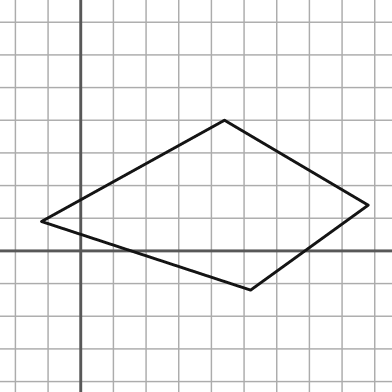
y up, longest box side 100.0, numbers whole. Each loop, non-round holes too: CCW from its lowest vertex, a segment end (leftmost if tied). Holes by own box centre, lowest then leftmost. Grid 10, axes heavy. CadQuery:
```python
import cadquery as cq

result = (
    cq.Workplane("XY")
    .moveTo(52.0, -12.0)
    .lineTo(88.0, 14.0)
    .lineTo(44.0, 40.0)
    .lineTo(-12.0, 9.0)
    .close()
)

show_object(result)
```